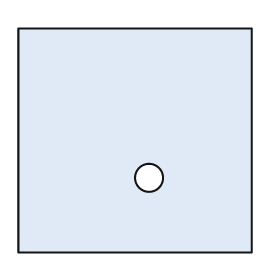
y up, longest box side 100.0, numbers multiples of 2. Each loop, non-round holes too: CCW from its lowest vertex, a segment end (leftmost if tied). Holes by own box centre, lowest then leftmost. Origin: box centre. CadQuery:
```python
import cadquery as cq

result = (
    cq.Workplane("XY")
    .moveTo(-50.0, -48.0)
    .lineTo(50.0, -48.0)
    .lineTo(50.0, 48.0)
    .lineTo(-50.0, 48.0)
    .close()
    .moveTo(6.0, -16.0)
    .circle(6.0)
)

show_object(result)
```